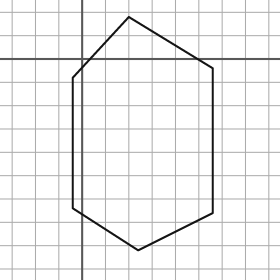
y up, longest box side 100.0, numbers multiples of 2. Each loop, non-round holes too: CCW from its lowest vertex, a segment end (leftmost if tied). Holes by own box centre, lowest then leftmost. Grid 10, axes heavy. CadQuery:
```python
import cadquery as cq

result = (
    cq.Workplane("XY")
    .moveTo(24.0, -82.0)
    .lineTo(56.0, -66.0)
    .lineTo(56.0, -4.0)
    .lineTo(20.0, 18.0)
    .lineTo(-4.0, -8.0)
    .lineTo(-4.0, -64.0)
    .close()
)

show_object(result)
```